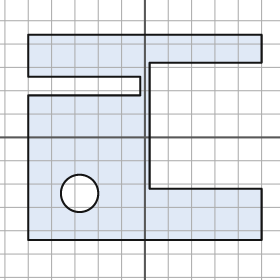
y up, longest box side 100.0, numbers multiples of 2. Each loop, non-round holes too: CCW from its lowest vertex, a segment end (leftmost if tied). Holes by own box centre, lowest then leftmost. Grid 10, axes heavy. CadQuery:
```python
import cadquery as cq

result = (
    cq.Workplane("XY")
    .moveTo(-50.0, -44.0)
    .lineTo(50.0, -44.0)
    .lineTo(50.0, -22.0)
    .lineTo(2.0, -22.0)
    .lineTo(2.0, 32.0)
    .lineTo(50.0, 32.0)
    .lineTo(50.0, 44.0)
    .lineTo(-50.0, 44.0)
    .lineTo(-50.0, 26.0)
    .lineTo(-2.0, 26.0)
    .lineTo(-2.0, 18.0)
    .lineTo(-50.0, 18.0)
    .close()
    .moveTo(-28.0, -24.0)
    .circle(8.0)
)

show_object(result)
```